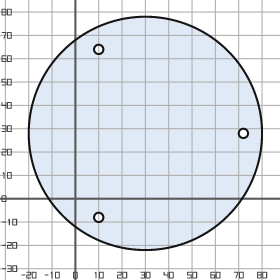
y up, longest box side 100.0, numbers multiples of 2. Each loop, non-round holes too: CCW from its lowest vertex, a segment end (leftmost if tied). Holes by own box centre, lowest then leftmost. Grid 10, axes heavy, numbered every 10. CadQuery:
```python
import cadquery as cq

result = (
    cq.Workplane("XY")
    .moveTo(30.0, 28.0)
    .circle(50.0)
    .moveTo(10.0, -8.0)
    .circle(2.0)
    .moveTo(72.0, 28.0)
    .circle(2.0)
    .moveTo(10.0, 64.0)
    .circle(2.0)
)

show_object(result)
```